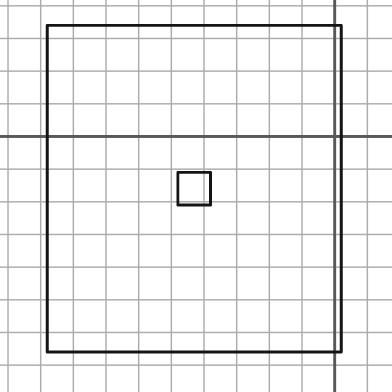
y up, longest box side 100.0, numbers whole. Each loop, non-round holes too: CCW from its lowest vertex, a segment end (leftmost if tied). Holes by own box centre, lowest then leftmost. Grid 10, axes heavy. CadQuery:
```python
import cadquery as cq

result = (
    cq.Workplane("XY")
    .moveTo(-88.0, -66.0)
    .lineTo(2.0, -66.0)
    .lineTo(2.0, 34.0)
    .lineTo(-88.0, 34.0)
    .close()
    .moveTo(-48.0, -21.0)
    .lineTo(-38.0, -21.0)
    .lineTo(-38.0, -11.0)
    .lineTo(-48.0, -11.0)
    .close()
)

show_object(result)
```